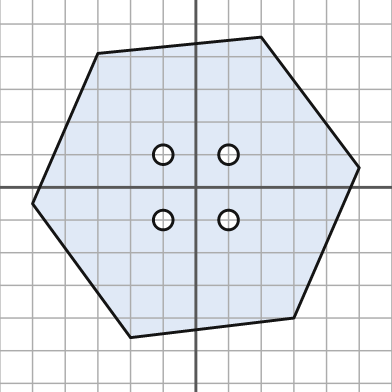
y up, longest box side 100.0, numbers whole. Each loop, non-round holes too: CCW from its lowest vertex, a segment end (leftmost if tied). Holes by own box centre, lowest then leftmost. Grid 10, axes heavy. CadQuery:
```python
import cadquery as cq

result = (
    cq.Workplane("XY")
    .moveTo(-20.0, -46.0)
    .lineTo(30.0, -40.0)
    .lineTo(50.0, 6.0)
    .lineTo(20.0, 46.0)
    .lineTo(-30.0, 41.0)
    .lineTo(-50.0, -5.0)
    .close()
    .moveTo(-10.0, -10.0)
    .circle(3.0)
    .moveTo(10.0, -10.0)
    .circle(3.0)
    .moveTo(-10.0, 10.0)
    .circle(3.0)
    .moveTo(10.0, 10.0)
    .circle(3.0)
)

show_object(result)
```